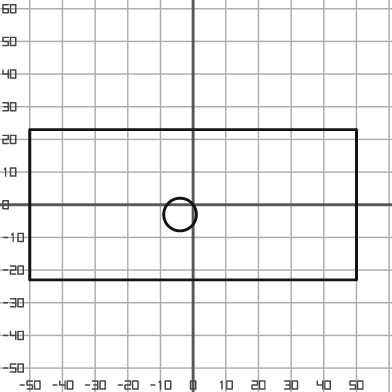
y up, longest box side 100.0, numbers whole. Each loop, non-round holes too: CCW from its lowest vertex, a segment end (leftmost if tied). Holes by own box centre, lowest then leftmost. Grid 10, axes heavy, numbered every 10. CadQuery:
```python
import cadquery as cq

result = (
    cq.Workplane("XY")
    .moveTo(-50.0, -23.0)
    .lineTo(50.0, -23.0)
    .lineTo(50.0, 23.0)
    .lineTo(-50.0, 23.0)
    .close()
    .moveTo(-4.0, -3.0)
    .circle(5.0)
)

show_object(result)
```